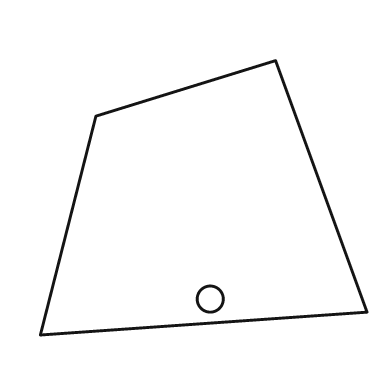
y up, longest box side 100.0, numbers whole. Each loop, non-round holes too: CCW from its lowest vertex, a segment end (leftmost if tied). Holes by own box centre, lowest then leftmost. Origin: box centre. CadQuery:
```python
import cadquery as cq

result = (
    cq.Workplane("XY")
    .moveTo(-50.0, -42.0)
    .lineTo(50.0, -35.0)
    .lineTo(22.0, 42.0)
    .lineTo(-33.0, 25.0)
    .close()
    .moveTo(2.0, -31.0)
    .circle(4.0)
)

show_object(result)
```